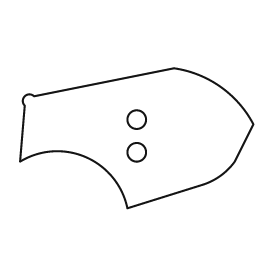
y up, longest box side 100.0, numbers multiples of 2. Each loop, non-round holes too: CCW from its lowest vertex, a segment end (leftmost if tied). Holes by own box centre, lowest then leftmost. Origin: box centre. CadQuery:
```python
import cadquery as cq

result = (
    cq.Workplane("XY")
    .moveTo(-4.0, -30.0)
    .lineTo(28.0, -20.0)
    .threePointArc((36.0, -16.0), (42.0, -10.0))
    .lineTo(50.0, 6.0)
    .threePointArc((36.0, 22.0), (16.0, 30.0))
    .lineTo(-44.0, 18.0)
    .threePointArc((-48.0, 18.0), (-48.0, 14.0))
    .lineTo(-50.0, -10.0)
    .threePointArc((-22.0, -8.0), (-4.0, -30.0))
    .close()
    .moveTo(0.0, -6.0)
    .circle(4.0)
    .moveTo(0.0, 8.0)
    .circle(4.0)
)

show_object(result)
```